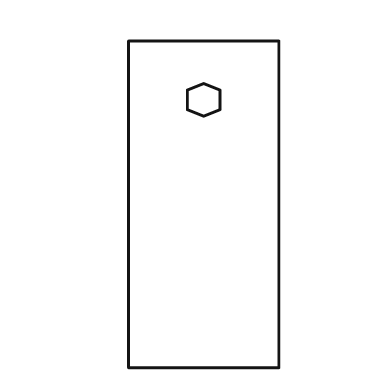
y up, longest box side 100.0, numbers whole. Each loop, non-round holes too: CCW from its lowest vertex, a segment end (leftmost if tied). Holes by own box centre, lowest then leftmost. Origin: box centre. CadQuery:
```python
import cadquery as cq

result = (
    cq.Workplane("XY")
    .moveTo(-23.0, -50.0)
    .lineTo(23.0, -50.0)
    .lineTo(23.0, 50.0)
    .lineTo(-23.0, 50.0)
    .close()
    .moveTo(0.0, 27.0)
    .lineTo(5.0, 29.0)
    .lineTo(5.0, 35.0)
    .lineTo(0.0, 37.0)
    .lineTo(-5.0, 35.0)
    .lineTo(-5.0, 29.0)
    .close()
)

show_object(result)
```